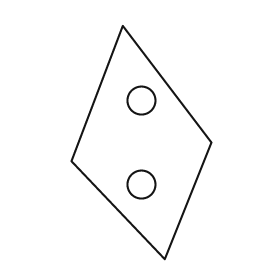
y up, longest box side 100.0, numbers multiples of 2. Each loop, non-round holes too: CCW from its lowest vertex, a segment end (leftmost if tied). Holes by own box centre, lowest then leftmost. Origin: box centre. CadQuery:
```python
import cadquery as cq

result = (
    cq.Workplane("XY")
    .moveTo(10.0, -50.0)
    .lineTo(30.0, 0.0)
    .lineTo(-8.0, 50.0)
    .lineTo(-30.0, -8.0)
    .close()
    .moveTo(0.0, -18.0)
    .circle(6.0)
    .moveTo(0.0, 18.0)
    .circle(6.0)
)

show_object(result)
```